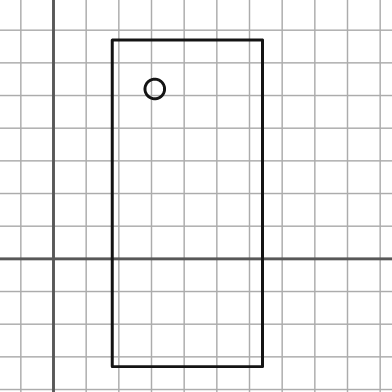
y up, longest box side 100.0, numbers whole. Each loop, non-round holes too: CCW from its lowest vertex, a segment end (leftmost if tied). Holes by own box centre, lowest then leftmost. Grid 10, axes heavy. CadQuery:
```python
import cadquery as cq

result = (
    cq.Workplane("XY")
    .moveTo(18.0, -33.0)
    .lineTo(64.0, -33.0)
    .lineTo(64.0, 67.0)
    .lineTo(18.0, 67.0)
    .close()
    .moveTo(31.0, 52.0)
    .circle(3.0)
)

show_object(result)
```